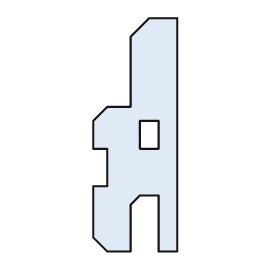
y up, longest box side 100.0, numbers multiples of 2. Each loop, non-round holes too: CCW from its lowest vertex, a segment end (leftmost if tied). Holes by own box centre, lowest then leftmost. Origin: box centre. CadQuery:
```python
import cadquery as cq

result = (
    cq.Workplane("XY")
    .moveTo(-12.0, -50.0)
    .lineTo(-2.0, -50.0)
    .lineTo(-2.0, -30.0)
    .lineTo(2.0, -26.0)
    .lineTo(10.0, -26.0)
    .lineTo(10.0, -50.0)
    .lineTo(18.0, -50.0)
    .lineTo(18.0, 50.0)
    .lineTo(6.0, 50.0)
    .lineTo(-2.0, 42.0)
    .lineTo(-2.0, 12.0)
    .lineTo(-12.0, 12.0)
    .lineTo(-18.0, 6.0)
    .lineTo(-18.0, -6.0)
    .lineTo(-12.0, -6.0)
    .lineTo(-12.0, -22.0)
    .lineTo(-18.0, -22.0)
    .lineTo(-18.0, -44.0)
    .close()
    .moveTo(2.0, -6.0)
    .lineTo(10.0, -6.0)
    .lineTo(10.0, 6.0)
    .lineTo(2.0, 6.0)
    .close()
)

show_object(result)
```